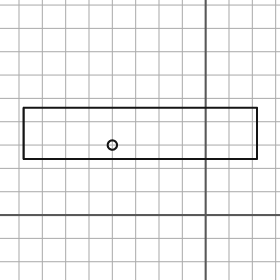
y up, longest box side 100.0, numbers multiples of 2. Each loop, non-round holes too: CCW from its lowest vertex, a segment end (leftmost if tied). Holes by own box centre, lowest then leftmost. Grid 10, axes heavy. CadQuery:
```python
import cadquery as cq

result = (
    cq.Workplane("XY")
    .moveTo(-78.0, 24.0)
    .lineTo(22.0, 24.0)
    .lineTo(22.0, 46.0)
    .lineTo(-78.0, 46.0)
    .close()
    .moveTo(-40.0, 30.0)
    .circle(2.0)
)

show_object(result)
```